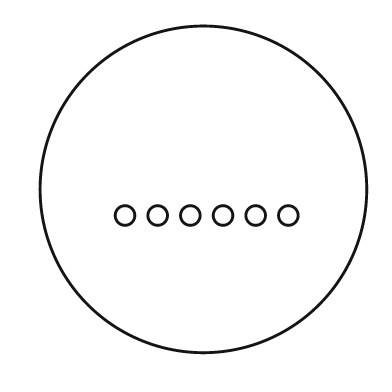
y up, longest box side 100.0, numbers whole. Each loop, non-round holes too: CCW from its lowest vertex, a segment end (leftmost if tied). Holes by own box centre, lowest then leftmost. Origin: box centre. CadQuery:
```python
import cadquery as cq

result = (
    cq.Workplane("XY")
    .moveTo(0.0, 0.0)
    .circle(50.0)
    .moveTo(-24.0, -8.0)
    .circle(3.0)
    .moveTo(-14.0, -8.0)
    .circle(3.0)
    .moveTo(-4.0, -8.0)
    .circle(3.0)
    .moveTo(6.0, -8.0)
    .circle(3.0)
    .moveTo(16.0, -8.0)
    .circle(3.0)
    .moveTo(26.0, -8.0)
    .circle(3.0)
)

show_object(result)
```